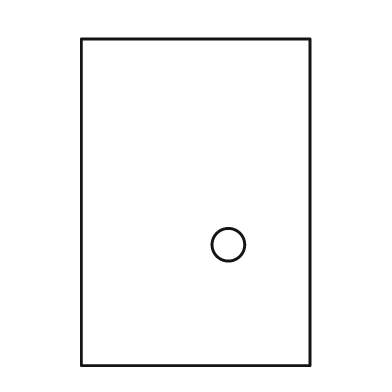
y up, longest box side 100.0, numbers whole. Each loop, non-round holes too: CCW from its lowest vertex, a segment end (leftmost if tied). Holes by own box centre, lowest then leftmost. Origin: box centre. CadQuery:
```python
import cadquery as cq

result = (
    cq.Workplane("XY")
    .moveTo(-35.0, -50.0)
    .lineTo(35.0, -50.0)
    .lineTo(35.0, 50.0)
    .lineTo(-35.0, 50.0)
    .close()
    .moveTo(10.0, -13.0)
    .circle(5.0)
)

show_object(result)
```